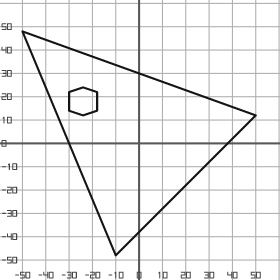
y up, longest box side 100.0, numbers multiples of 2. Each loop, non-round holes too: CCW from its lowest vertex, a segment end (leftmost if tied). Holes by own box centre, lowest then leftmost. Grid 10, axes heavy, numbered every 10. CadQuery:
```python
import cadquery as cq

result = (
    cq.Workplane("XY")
    .moveTo(-10.0, -48.0)
    .lineTo(50.0, 12.0)
    .lineTo(-50.0, 48.0)
    .close()
    .moveTo(-24.0, 12.0)
    .lineTo(-18.0, 14.0)
    .lineTo(-18.0, 22.0)
    .lineTo(-24.0, 24.0)
    .lineTo(-30.0, 22.0)
    .lineTo(-30.0, 14.0)
    .close()
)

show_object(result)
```